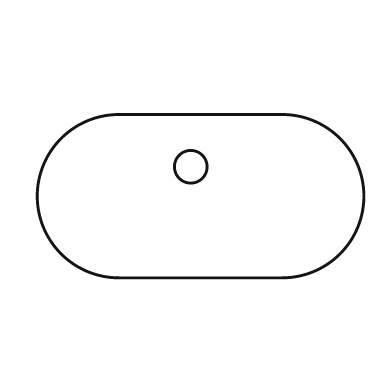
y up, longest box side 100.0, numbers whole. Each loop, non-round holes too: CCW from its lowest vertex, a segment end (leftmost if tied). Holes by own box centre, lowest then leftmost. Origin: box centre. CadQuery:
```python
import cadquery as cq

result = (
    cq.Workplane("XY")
    .moveTo(-25.0, -25.0)
    .lineTo(25.0, -25.0)
    .threePointArc((50.0, 0.0), (25.0, 25.0))
    .lineTo(-25.0, 25.0)
    .threePointArc((-50.0, 0.0), (-25.0, -25.0))
    .close()
    .moveTo(-3.0, 9.0)
    .circle(5.0)
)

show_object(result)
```